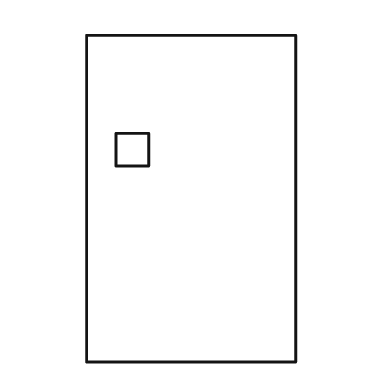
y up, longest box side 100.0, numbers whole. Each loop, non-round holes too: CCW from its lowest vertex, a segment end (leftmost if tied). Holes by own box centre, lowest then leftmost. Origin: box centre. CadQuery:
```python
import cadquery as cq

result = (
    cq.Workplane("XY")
    .moveTo(-32.0, -50.0)
    .lineTo(32.0, -50.0)
    .lineTo(32.0, 50.0)
    .lineTo(-32.0, 50.0)
    .close()
    .moveTo(-23.0, 10.0)
    .lineTo(-13.0, 10.0)
    .lineTo(-13.0, 20.0)
    .lineTo(-23.0, 20.0)
    .close()
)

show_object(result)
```